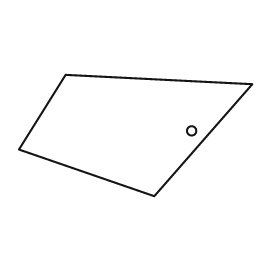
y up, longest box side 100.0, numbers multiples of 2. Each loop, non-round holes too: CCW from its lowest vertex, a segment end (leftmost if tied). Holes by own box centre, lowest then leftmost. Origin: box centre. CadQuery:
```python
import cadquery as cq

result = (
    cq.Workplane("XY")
    .moveTo(8.0, -26.0)
    .lineTo(50.0, 22.0)
    .lineTo(-30.0, 26.0)
    .lineTo(-50.0, -6.0)
    .close()
    .moveTo(24.0, 2.0)
    .circle(2.0)
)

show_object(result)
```